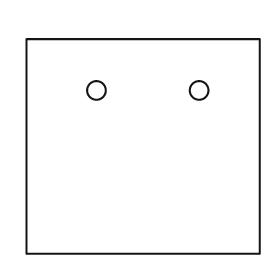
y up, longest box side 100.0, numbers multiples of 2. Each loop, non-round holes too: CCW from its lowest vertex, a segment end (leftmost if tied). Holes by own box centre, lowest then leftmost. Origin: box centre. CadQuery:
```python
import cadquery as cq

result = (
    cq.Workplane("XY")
    .moveTo(-50.0, -46.0)
    .lineTo(50.0, -46.0)
    .lineTo(50.0, 46.0)
    .lineTo(-50.0, 46.0)
    .close()
    .moveTo(-20.0, 24.0)
    .circle(4.0)
    .moveTo(24.0, 24.0)
    .circle(4.0)
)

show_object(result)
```